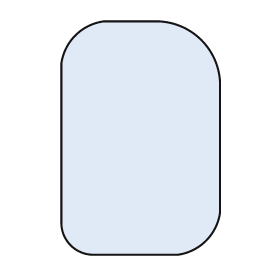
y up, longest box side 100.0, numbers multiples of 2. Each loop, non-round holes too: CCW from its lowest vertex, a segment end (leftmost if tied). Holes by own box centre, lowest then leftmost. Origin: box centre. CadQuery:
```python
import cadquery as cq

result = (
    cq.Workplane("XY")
    .moveTo(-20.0, -50.0)
    .lineTo(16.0, -50.0)
    .threePointArc((28.0, -44.0), (34.0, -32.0))
    .lineTo(34.0, 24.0)
    .threePointArc((26.0, 42.0), (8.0, 50.0))
    .lineTo(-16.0, 50.0)
    .threePointArc((-28.0, 44.0), (-34.0, 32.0))
    .lineTo(-34.0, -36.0)
    .threePointArc((-30.0, -46.0), (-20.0, -50.0))
    .close()
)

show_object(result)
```